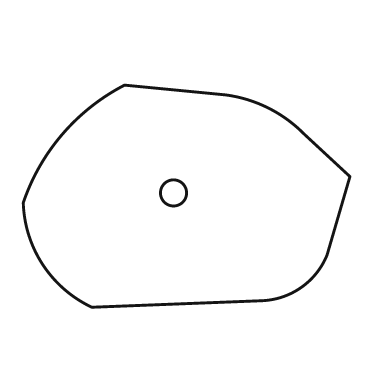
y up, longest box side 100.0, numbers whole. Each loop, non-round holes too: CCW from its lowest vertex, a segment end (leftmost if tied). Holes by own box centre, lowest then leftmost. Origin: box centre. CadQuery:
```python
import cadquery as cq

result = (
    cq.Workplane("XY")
    .moveTo(-29.0, -34.0)
    .lineTo(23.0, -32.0)
    .threePointArc((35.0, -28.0), (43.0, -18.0))
    .lineTo(50.0, 6.0)
    .lineTo(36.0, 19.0)
    .threePointArc((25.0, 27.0), (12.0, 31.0))
    .lineTo(-19.0, 34.0)
    .threePointArc((-38.0, 19.0), (-50.0, -2.0))
    .threePointArc((-44.0, -21.0), (-29.0, -34.0))
    .close()
    .moveTo(-4.0, 1.0)
    .circle(4.0)
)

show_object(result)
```